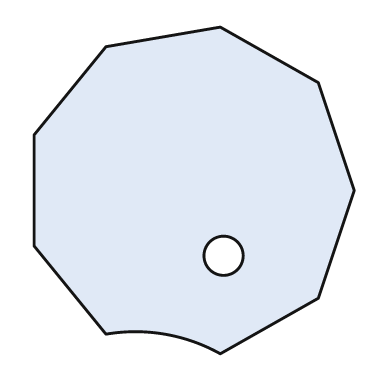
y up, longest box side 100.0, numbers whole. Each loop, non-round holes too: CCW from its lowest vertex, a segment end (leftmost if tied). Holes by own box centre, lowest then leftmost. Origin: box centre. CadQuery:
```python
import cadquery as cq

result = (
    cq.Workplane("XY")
    .moveTo(8.0, -50.0)
    .lineTo(38.0, -33.0)
    .lineTo(49.0, 0.0)
    .lineTo(38.0, 33.0)
    .lineTo(8.0, 50.0)
    .lineTo(-27.0, 44.0)
    .lineTo(-49.0, 17.0)
    .lineTo(-49.0, -17.0)
    .lineTo(-27.0, -44.0)
    .threePointArc((-9.0, -44.0), (8.0, -50.0))
    .close()
    .moveTo(9.0, -20.0)
    .circle(6.0)
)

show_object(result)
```